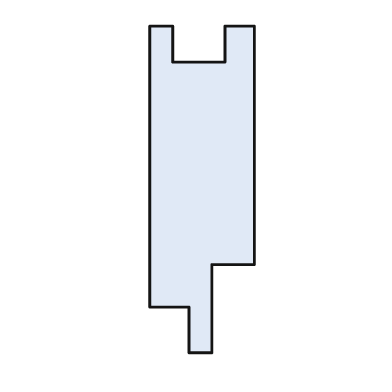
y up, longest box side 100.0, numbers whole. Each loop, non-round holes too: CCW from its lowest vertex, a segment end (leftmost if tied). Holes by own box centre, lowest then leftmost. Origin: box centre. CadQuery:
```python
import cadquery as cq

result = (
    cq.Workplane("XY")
    .moveTo(-4.0, -50.0)
    .lineTo(3.0, -50.0)
    .lineTo(3.0, -23.0)
    .lineTo(16.0, -23.0)
    .lineTo(16.0, 50.0)
    .lineTo(7.0, 50.0)
    .lineTo(7.0, 39.0)
    .lineTo(-9.0, 39.0)
    .lineTo(-9.0, 50.0)
    .lineTo(-16.0, 50.0)
    .lineTo(-16.0, -36.0)
    .lineTo(-4.0, -36.0)
    .close()
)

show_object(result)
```